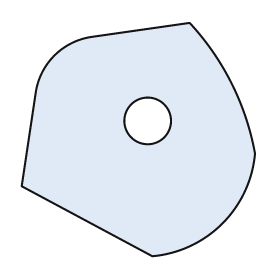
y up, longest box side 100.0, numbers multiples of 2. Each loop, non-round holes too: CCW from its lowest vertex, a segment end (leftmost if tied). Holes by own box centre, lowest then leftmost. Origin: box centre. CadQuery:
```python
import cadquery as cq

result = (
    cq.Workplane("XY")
    .moveTo(6.0, -50.0)
    .threePointArc((36.0, -36.0), (50.0, -6.0))
    .threePointArc((40.0, 24.0), (22.0, 50.0))
    .lineTo(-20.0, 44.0)
    .threePointArc((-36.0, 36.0), (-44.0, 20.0))
    .lineTo(-50.0, -20.0)
    .close()
    .moveTo(4.0, 8.0)
    .circle(10.0)
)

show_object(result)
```